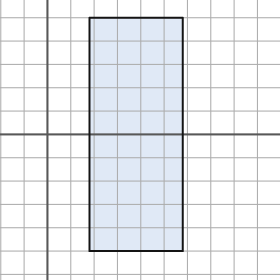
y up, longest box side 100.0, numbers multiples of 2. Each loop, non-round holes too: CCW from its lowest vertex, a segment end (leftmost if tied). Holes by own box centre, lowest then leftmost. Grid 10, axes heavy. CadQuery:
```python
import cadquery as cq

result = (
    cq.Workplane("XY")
    .moveTo(18.0, -50.0)
    .lineTo(58.0, -50.0)
    .lineTo(58.0, 50.0)
    .lineTo(18.0, 50.0)
    .close()
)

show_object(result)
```